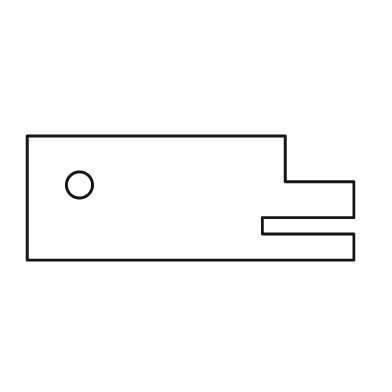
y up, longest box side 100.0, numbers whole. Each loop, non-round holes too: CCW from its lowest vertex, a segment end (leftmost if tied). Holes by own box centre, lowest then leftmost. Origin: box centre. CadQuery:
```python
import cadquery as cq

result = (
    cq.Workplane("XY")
    .moveTo(-50.0, -19.0)
    .lineTo(50.0, -19.0)
    .lineTo(50.0, -11.0)
    .lineTo(22.0, -11.0)
    .lineTo(22.0, -6.0)
    .lineTo(50.0, -6.0)
    .lineTo(50.0, 5.0)
    .lineTo(29.0, 5.0)
    .lineTo(29.0, 19.0)
    .lineTo(-50.0, 19.0)
    .close()
    .moveTo(-34.0, 4.0)
    .circle(4.0)
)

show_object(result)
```